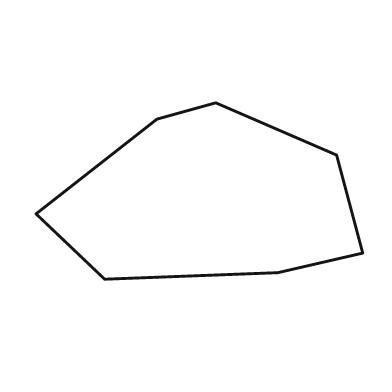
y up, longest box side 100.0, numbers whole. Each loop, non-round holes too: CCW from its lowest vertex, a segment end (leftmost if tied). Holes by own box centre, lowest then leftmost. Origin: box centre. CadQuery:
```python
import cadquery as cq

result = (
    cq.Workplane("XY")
    .moveTo(-29.0, -27.0)
    .lineTo(24.0, -25.0)
    .lineTo(50.0, -19.0)
    .lineTo(42.0, 11.0)
    .lineTo(5.0, 27.0)
    .lineTo(-13.0, 22.0)
    .lineTo(-50.0, -7.0)
    .close()
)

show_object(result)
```